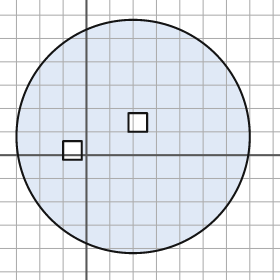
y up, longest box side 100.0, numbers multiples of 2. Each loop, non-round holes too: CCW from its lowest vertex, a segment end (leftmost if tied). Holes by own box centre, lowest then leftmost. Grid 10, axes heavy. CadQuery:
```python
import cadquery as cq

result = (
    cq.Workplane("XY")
    .moveTo(20.0, 8.0)
    .circle(50.0)
    .moveTo(-10.0, -2.0)
    .lineTo(-2.0, -2.0)
    .lineTo(-2.0, 6.0)
    .lineTo(-10.0, 6.0)
    .close()
    .moveTo(18.0, 10.0)
    .lineTo(26.0, 10.0)
    .lineTo(26.0, 18.0)
    .lineTo(18.0, 18.0)
    .close()
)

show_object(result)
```